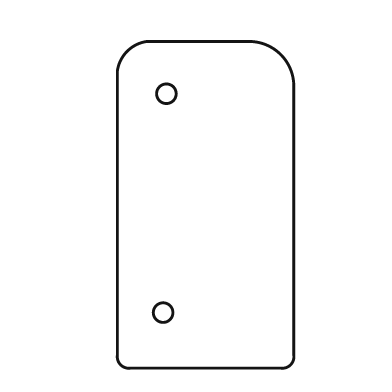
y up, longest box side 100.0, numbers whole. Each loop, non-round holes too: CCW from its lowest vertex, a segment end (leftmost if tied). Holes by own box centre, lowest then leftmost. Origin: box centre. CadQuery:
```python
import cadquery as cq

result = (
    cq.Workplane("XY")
    .moveTo(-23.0, -50.0)
    .lineTo(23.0, -50.0)
    .threePointArc((26.0, -49.0), (27.0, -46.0))
    .lineTo(27.0, 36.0)
    .threePointArc((23.0, 46.0), (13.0, 50.0))
    .lineTo(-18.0, 50.0)
    .threePointArc((-24.0, 47.0), (-27.0, 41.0))
    .lineTo(-27.0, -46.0)
    .threePointArc((-26.0, -49.0), (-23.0, -50.0))
    .close()
    .moveTo(-13.0, -33.0)
    .circle(3.0)
    .moveTo(-12.0, 34.0)
    .circle(3.0)
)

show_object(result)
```